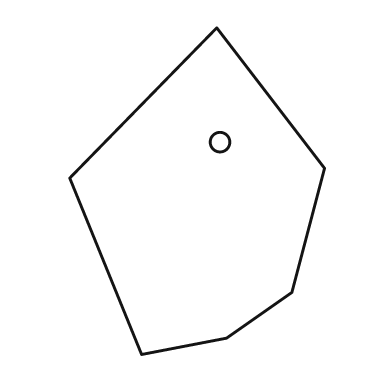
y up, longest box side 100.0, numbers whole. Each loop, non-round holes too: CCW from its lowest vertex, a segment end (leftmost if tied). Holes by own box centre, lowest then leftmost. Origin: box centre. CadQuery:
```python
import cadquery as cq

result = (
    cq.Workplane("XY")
    .moveTo(-17.0, -50.0)
    .lineTo(9.0, -45.0)
    .lineTo(29.0, -31.0)
    .lineTo(39.0, 7.0)
    .lineTo(6.0, 50.0)
    .lineTo(-39.0, 4.0)
    .close()
    .moveTo(7.0, 15.0)
    .circle(3.0)
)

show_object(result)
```